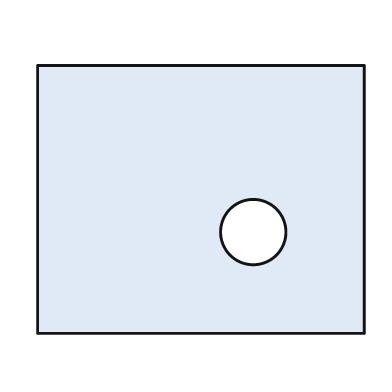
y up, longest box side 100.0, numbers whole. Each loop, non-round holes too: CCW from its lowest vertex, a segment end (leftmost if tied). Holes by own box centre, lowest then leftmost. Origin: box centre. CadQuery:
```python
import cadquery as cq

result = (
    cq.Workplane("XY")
    .moveTo(-50.0, -41.0)
    .lineTo(50.0, -41.0)
    .lineTo(50.0, 41.0)
    .lineTo(-50.0, 41.0)
    .close()
    .moveTo(16.0, -10.0)
    .circle(10.0)
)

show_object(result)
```